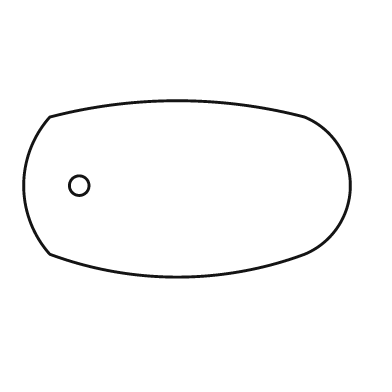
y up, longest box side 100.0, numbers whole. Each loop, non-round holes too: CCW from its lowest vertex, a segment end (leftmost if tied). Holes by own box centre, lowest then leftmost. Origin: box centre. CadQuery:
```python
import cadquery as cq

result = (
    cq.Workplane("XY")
    .moveTo(-42.0, -20.0)
    .threePointArc((-3.0, -27.0), (36.0, -20.0))
    .threePointArc((50.0, 1.0), (36.0, 22.0))
    .threePointArc((-3.0, 27.0), (-42.0, 22.0))
    .threePointArc((-50.0, 1.0), (-42.0, -20.0))
    .close()
    .moveTo(-33.0, 1.0)
    .circle(3.0)
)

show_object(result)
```